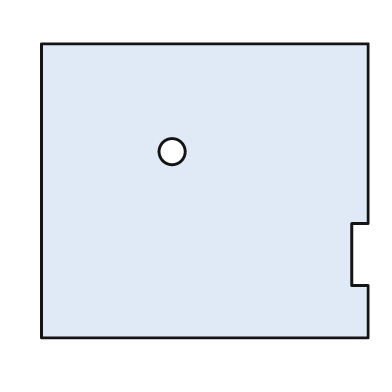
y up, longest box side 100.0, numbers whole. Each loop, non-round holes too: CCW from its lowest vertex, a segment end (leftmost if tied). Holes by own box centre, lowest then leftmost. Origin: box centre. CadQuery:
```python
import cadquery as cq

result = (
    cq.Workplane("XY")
    .moveTo(-50.0, -45.0)
    .lineTo(50.0, -45.0)
    .lineTo(50.0, -29.0)
    .lineTo(45.0, -29.0)
    .lineTo(45.0, -10.0)
    .lineTo(50.0, -10.0)
    .lineTo(50.0, 45.0)
    .lineTo(-50.0, 45.0)
    .close()
    .moveTo(-10.0, 12.0)
    .circle(4.0)
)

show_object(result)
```